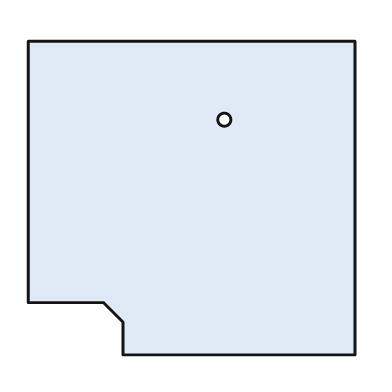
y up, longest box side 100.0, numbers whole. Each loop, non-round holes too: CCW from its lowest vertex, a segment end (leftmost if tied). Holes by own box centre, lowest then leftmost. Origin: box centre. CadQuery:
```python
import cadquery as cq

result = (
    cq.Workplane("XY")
    .moveTo(-21.0, -48.0)
    .lineTo(50.0, -48.0)
    .lineTo(50.0, 48.0)
    .lineTo(-50.0, 48.0)
    .lineTo(-50.0, -32.0)
    .lineTo(-27.0, -32.0)
    .lineTo(-21.0, -38.0)
    .close()
    .moveTo(10.0, 24.0)
    .circle(2.0)
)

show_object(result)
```